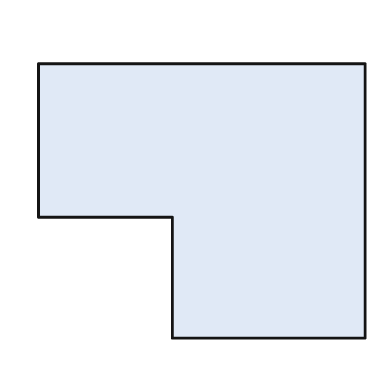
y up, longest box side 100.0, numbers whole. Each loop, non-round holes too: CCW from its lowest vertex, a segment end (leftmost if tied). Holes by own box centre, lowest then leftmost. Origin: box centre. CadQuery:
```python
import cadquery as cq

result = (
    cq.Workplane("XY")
    .moveTo(-9.0, -42.0)
    .lineTo(50.0, -42.0)
    .lineTo(50.0, 42.0)
    .lineTo(-50.0, 42.0)
    .lineTo(-50.0, -5.0)
    .lineTo(-9.0, -5.0)
    .close()
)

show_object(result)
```